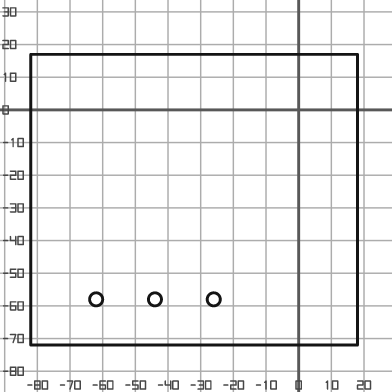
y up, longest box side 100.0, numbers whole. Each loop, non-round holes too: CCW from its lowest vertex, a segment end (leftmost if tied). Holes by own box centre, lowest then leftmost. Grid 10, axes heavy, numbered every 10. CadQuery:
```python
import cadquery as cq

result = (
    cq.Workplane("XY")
    .moveTo(-82.0, -72.0)
    .lineTo(18.0, -72.0)
    .lineTo(18.0, 17.0)
    .lineTo(-82.0, 17.0)
    .close()
    .moveTo(-62.0, -58.0)
    .circle(2.0)
    .moveTo(-44.0, -58.0)
    .circle(2.0)
    .moveTo(-26.0, -58.0)
    .circle(2.0)
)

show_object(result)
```